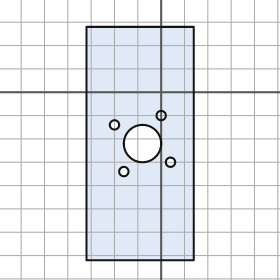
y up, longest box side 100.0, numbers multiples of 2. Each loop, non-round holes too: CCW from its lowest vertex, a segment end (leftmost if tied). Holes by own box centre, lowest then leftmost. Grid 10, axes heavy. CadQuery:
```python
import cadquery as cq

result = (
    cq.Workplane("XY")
    .moveTo(-32.0, -72.0)
    .lineTo(14.0, -72.0)
    .lineTo(14.0, 28.0)
    .lineTo(-32.0, 28.0)
    .close()
    .moveTo(-16.0, -34.0)
    .circle(2.0)
    .moveTo(4.0, -30.0)
    .circle(2.0)
    .moveTo(-8.0, -22.0)
    .circle(8.0)
    .moveTo(-20.0, -14.0)
    .circle(2.0)
    .moveTo(0.0, -10.0)
    .circle(2.0)
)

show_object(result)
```